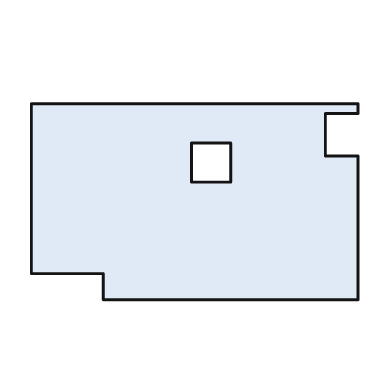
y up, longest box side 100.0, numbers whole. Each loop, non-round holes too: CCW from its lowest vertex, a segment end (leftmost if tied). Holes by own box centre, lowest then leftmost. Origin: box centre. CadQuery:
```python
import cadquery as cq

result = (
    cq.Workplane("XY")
    .moveTo(-28.0, -30.0)
    .lineTo(50.0, -30.0)
    .lineTo(50.0, 14.0)
    .lineTo(40.0, 14.0)
    .lineTo(40.0, 27.0)
    .lineTo(50.0, 27.0)
    .lineTo(50.0, 30.0)
    .lineTo(-50.0, 30.0)
    .lineTo(-50.0, -22.0)
    .lineTo(-28.0, -22.0)
    .close()
    .moveTo(-1.0, 6.0)
    .lineTo(11.0, 6.0)
    .lineTo(11.0, 18.0)
    .lineTo(-1.0, 18.0)
    .close()
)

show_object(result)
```